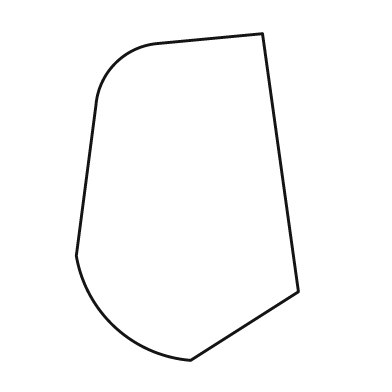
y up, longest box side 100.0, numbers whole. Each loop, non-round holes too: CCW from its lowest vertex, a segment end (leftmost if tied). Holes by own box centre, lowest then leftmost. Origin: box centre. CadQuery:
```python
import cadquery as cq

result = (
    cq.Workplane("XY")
    .moveTo(1.0, -50.0)
    .lineTo(34.0, -29.0)
    .lineTo(23.0, 50.0)
    .lineTo(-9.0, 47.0)
    .threePointArc((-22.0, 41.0), (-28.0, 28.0))
    .lineTo(-34.0, -18.0)
    .threePointArc((-22.0, -40.0), (1.0, -50.0))
    .close()
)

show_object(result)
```